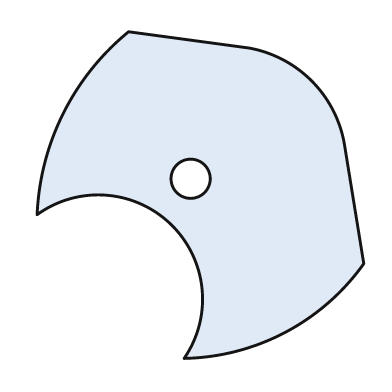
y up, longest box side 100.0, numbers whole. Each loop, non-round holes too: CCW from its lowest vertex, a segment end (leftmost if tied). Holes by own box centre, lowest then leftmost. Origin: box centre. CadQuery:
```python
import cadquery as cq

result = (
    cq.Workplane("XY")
    .moveTo(-5.0, -50.0)
    .threePointArc((26.0, -42.0), (50.0, -21.0))
    .lineTo(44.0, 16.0)
    .threePointArc((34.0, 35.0), (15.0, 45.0))
    .lineTo(-22.0, 50.0)
    .threePointArc((-42.0, 25.0), (-50.0, -6.0))
    .threePointArc((-9.0, -9.0), (-5.0, -50.0))
    .close()
    .moveTo(-3.0, 5.0)
    .circle(6.0)
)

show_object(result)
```